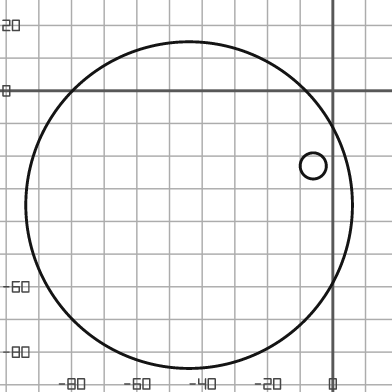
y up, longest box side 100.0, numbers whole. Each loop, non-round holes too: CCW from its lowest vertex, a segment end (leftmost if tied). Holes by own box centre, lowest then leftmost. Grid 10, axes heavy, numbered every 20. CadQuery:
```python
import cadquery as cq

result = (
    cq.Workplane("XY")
    .moveTo(-44.0, -35.0)
    .circle(50.0)
    .moveTo(-6.0, -23.0)
    .circle(4.0)
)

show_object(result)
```